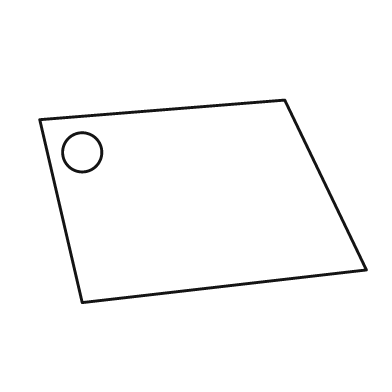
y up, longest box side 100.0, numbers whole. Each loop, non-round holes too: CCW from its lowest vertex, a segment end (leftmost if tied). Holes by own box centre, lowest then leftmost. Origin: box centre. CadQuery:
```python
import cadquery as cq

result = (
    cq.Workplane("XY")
    .moveTo(-37.0, -31.0)
    .lineTo(50.0, -21.0)
    .lineTo(25.0, 31.0)
    .lineTo(-50.0, 25.0)
    .close()
    .moveTo(-37.0, 15.0)
    .circle(6.0)
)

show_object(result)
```